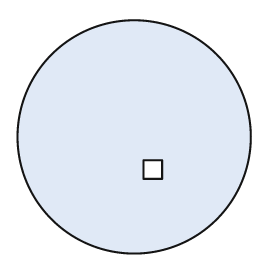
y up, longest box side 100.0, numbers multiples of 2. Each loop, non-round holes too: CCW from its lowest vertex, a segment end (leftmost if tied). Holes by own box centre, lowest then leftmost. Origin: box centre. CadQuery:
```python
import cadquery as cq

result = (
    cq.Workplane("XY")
    .moveTo(0.0, 0.0)
    .circle(50.0)
    .moveTo(4.0, -18.0)
    .lineTo(12.0, -18.0)
    .lineTo(12.0, -10.0)
    .lineTo(4.0, -10.0)
    .close()
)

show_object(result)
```